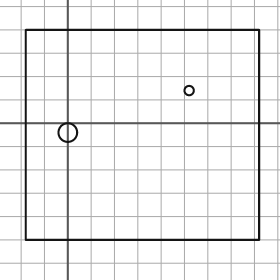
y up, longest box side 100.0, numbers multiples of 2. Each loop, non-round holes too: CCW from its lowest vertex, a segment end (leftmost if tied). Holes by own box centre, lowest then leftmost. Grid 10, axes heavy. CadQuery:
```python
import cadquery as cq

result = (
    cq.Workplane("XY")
    .moveTo(-18.0, -50.0)
    .lineTo(82.0, -50.0)
    .lineTo(82.0, 40.0)
    .lineTo(-18.0, 40.0)
    .close()
    .moveTo(0.0, -4.0)
    .circle(4.0)
    .moveTo(52.0, 14.0)
    .circle(2.0)
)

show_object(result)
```